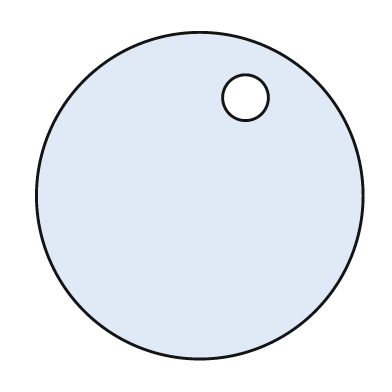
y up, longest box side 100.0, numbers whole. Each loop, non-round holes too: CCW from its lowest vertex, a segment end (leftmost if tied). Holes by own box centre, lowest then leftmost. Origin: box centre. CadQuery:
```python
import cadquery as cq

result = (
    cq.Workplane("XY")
    .moveTo(0.0, 0.0)
    .circle(50.0)
    .moveTo(14.0, 30.0)
    .circle(7.0)
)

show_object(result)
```